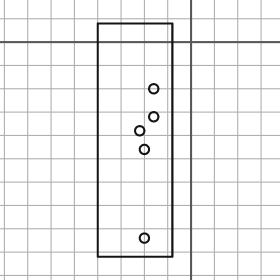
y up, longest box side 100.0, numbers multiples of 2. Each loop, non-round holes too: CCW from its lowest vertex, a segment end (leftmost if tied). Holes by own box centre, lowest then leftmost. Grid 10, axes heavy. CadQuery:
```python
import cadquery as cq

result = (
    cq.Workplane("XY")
    .moveTo(-40.0, -92.0)
    .lineTo(-8.0, -92.0)
    .lineTo(-8.0, 8.0)
    .lineTo(-40.0, 8.0)
    .close()
    .moveTo(-20.0, -84.0)
    .circle(2.0)
    .moveTo(-20.0, -46.0)
    .circle(2.0)
    .moveTo(-22.0, -38.0)
    .circle(2.0)
    .moveTo(-16.0, -32.0)
    .circle(2.0)
    .moveTo(-16.0, -20.0)
    .circle(2.0)
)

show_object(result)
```